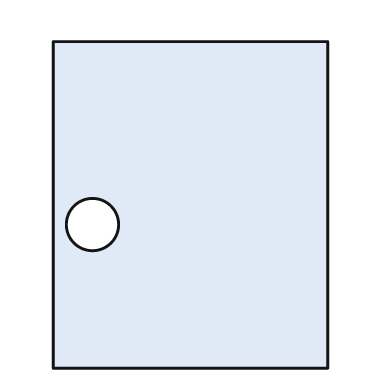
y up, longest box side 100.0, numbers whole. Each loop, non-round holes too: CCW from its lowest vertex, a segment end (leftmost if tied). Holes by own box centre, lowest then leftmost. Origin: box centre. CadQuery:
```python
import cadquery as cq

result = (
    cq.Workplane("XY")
    .moveTo(-42.0, -50.0)
    .lineTo(42.0, -50.0)
    .lineTo(42.0, 50.0)
    .lineTo(-42.0, 50.0)
    .close()
    .moveTo(-30.0, -6.0)
    .circle(8.0)
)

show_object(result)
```